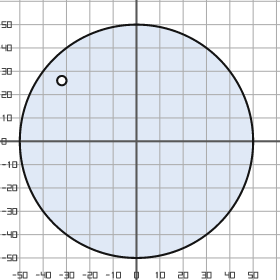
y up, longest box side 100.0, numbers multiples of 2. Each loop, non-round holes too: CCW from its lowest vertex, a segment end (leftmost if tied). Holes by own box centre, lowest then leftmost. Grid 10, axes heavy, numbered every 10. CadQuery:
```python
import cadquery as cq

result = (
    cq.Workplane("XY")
    .moveTo(0.0, 0.0)
    .circle(50.0)
    .moveTo(-32.0, 26.0)
    .circle(2.0)
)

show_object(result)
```